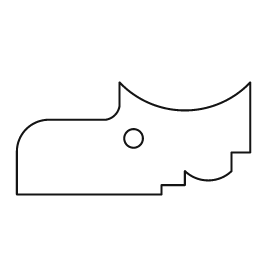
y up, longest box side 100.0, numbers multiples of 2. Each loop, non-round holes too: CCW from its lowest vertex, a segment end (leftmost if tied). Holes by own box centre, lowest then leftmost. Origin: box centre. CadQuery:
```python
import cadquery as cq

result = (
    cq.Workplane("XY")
    .moveTo(-50.0, -24.0)
    .lineTo(12.0, -24.0)
    .lineTo(12.0, -20.0)
    .lineTo(22.0, -20.0)
    .lineTo(22.0, -14.0)
    .threePointArc((32.0, -18.0), (42.0, -14.0))
    .lineTo(42.0, -6.0)
    .lineTo(50.0, -6.0)
    .lineTo(50.0, 24.0)
    .threePointArc((22.0, 12.0), (-6.0, 24.0))
    .lineTo(-6.0, 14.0)
    .threePointArc((-8.0, 10.0), (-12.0, 8.0))
    .lineTo(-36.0, 8.0)
    .threePointArc((-46.0, 4.0), (-50.0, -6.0))
    .close()
    .moveTo(0.0, 0.0)
    .circle(4.0)
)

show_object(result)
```